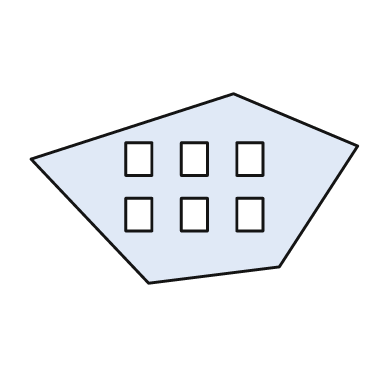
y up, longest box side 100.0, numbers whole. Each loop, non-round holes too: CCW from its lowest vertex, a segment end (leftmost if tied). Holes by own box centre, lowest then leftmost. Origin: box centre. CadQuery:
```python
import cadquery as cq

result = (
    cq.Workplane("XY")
    .moveTo(-14.0, -29.0)
    .lineTo(26.0, -24.0)
    .lineTo(50.0, 13.0)
    .lineTo(12.0, 29.0)
    .lineTo(-50.0, 9.0)
    .close()
    .moveTo(-21.0, -13.0)
    .lineTo(-13.0, -13.0)
    .lineTo(-13.0, -3.0)
    .lineTo(-21.0, -3.0)
    .close()
    .moveTo(-4.0, -13.0)
    .lineTo(4.0, -13.0)
    .lineTo(4.0, -3.0)
    .lineTo(-4.0, -3.0)
    .close()
    .moveTo(13.0, -13.0)
    .lineTo(21.0, -13.0)
    .lineTo(21.0, -3.0)
    .lineTo(13.0, -3.0)
    .close()
    .moveTo(-21.0, 4.0)
    .lineTo(-13.0, 4.0)
    .lineTo(-13.0, 14.0)
    .lineTo(-21.0, 14.0)
    .close()
    .moveTo(-4.0, 4.0)
    .lineTo(4.0, 4.0)
    .lineTo(4.0, 14.0)
    .lineTo(-4.0, 14.0)
    .close()
    .moveTo(13.0, 4.0)
    .lineTo(21.0, 4.0)
    .lineTo(21.0, 14.0)
    .lineTo(13.0, 14.0)
    .close()
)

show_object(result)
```